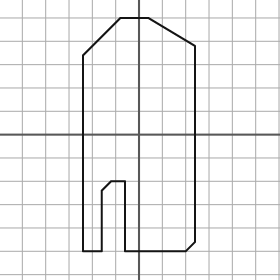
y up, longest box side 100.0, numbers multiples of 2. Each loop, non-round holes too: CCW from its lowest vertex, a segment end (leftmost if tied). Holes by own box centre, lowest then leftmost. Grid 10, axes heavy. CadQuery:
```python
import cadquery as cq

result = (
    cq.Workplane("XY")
    .moveTo(-24.0, -50.0)
    .lineTo(-16.0, -50.0)
    .lineTo(-16.0, -24.0)
    .lineTo(-12.0, -20.0)
    .lineTo(-6.0, -20.0)
    .lineTo(-6.0, -50.0)
    .lineTo(20.0, -50.0)
    .lineTo(24.0, -46.0)
    .lineTo(24.0, 38.0)
    .lineTo(4.0, 50.0)
    .lineTo(-8.0, 50.0)
    .lineTo(-24.0, 34.0)
    .close()
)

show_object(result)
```